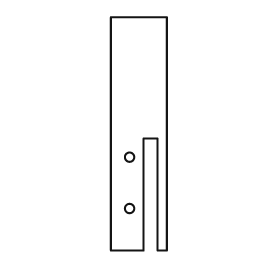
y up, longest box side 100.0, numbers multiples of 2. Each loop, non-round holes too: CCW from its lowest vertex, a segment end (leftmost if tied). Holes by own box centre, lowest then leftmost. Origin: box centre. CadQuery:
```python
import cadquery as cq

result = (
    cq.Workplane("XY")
    .moveTo(-12.0, -50.0)
    .lineTo(2.0, -50.0)
    .lineTo(2.0, -2.0)
    .lineTo(8.0, -2.0)
    .lineTo(8.0, -50.0)
    .lineTo(12.0, -50.0)
    .lineTo(12.0, 50.0)
    .lineTo(-12.0, 50.0)
    .close()
    .moveTo(-4.0, -32.0)
    .circle(2.0)
    .moveTo(-4.0, -10.0)
    .circle(2.0)
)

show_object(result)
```